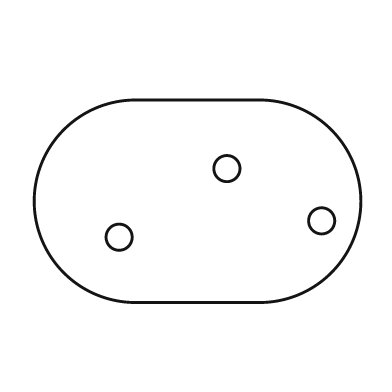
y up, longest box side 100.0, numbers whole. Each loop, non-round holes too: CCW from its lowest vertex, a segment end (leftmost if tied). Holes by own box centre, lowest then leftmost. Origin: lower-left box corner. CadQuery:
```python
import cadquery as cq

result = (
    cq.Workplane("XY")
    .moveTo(31.0, 0.0)
    .lineTo(69.0, 0.0)
    .threePointArc((100.0, 31.0), (69.0, 62.0))
    .lineTo(31.0, 62.0)
    .threePointArc((0.0, 31.0), (31.0, 0.0))
    .close()
    .moveTo(26.0, 20.0)
    .circle(4.0)
    .moveTo(88.0, 25.0)
    .circle(4.0)
    .moveTo(59.0, 41.0)
    .circle(4.0)
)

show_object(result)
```